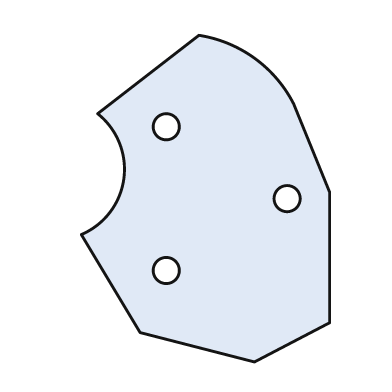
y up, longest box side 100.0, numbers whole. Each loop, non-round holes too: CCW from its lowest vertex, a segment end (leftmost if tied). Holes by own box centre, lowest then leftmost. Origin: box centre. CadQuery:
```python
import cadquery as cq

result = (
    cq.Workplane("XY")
    .moveTo(15.0, -50.0)
    .lineTo(38.0, -38.0)
    .lineTo(38.0, 2.0)
    .lineTo(27.0, 29.0)
    .threePointArc((15.0, 43.0), (-2.0, 50.0))
    .lineTo(-33.0, 26.0)
    .threePointArc((-25.0, 6.0), (-38.0, -11.0))
    .lineTo(-20.0, -41.0)
    .close()
    .moveTo(-12.0, -22.0)
    .circle(4.0)
    .moveTo(25.0, 0.0)
    .circle(4.0)
    .moveTo(-12.0, 22.0)
    .circle(4.0)
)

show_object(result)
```